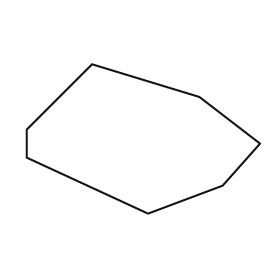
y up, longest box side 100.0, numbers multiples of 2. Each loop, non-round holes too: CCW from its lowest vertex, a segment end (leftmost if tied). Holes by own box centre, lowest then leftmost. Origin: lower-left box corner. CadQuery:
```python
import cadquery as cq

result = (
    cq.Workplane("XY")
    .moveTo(52.0, 0.0)
    .lineTo(84.0, 12.0)
    .lineTo(100.0, 30.0)
    .lineTo(74.0, 50.0)
    .lineTo(28.0, 64.0)
    .lineTo(0.0, 36.0)
    .lineTo(0.0, 24.0)
    .close()
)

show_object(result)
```